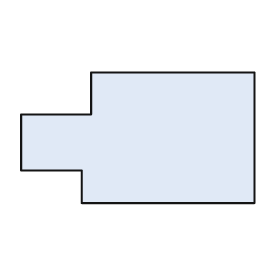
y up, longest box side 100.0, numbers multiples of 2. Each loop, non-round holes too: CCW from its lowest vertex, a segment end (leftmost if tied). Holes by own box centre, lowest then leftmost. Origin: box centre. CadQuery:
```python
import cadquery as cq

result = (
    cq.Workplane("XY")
    .moveTo(-24.0, -28.0)
    .lineTo(50.0, -28.0)
    .lineTo(50.0, 28.0)
    .lineTo(-20.0, 28.0)
    .lineTo(-20.0, 10.0)
    .lineTo(-50.0, 10.0)
    .lineTo(-50.0, -14.0)
    .lineTo(-24.0, -14.0)
    .close()
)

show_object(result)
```